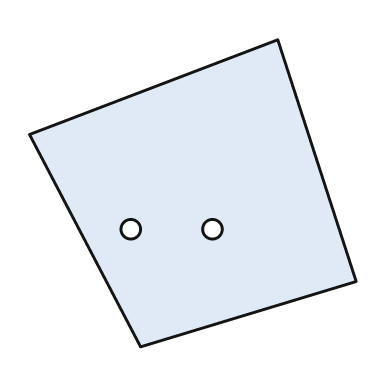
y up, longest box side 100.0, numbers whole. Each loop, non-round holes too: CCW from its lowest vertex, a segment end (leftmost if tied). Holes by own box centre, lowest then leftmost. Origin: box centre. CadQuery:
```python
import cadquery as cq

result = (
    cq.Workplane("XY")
    .moveTo(-16.0, -47.0)
    .lineTo(50.0, -27.0)
    .lineTo(26.0, 47.0)
    .lineTo(-50.0, 18.0)
    .close()
    .moveTo(-19.0, -11.0)
    .circle(3.0)
    .moveTo(6.0, -11.0)
    .circle(3.0)
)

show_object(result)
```